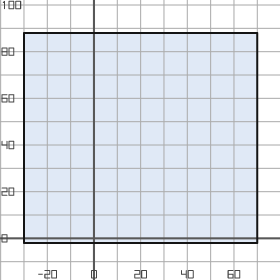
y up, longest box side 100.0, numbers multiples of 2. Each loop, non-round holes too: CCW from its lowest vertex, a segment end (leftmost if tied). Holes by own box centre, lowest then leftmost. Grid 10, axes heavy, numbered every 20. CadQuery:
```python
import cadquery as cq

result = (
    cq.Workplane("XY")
    .moveTo(-30.0, -2.0)
    .lineTo(70.0, -2.0)
    .lineTo(70.0, 88.0)
    .lineTo(-30.0, 88.0)
    .close()
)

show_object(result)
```